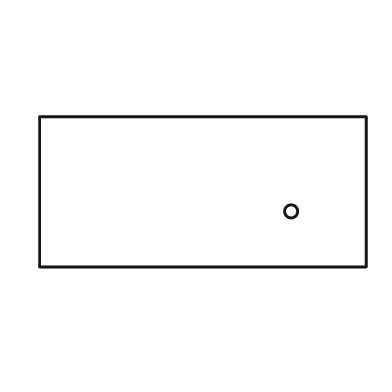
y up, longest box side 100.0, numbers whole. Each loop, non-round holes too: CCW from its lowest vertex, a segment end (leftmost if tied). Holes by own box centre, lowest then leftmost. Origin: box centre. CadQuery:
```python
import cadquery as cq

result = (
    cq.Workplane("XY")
    .moveTo(-50.0, -23.0)
    .lineTo(50.0, -23.0)
    .lineTo(50.0, 23.0)
    .lineTo(-50.0, 23.0)
    .close()
    .moveTo(27.0, -6.0)
    .circle(2.0)
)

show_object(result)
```